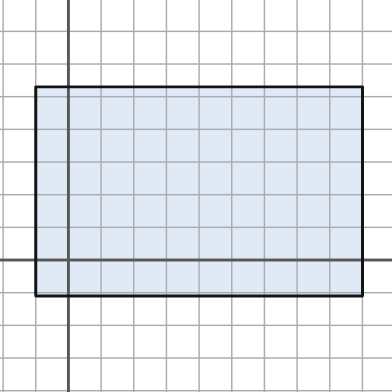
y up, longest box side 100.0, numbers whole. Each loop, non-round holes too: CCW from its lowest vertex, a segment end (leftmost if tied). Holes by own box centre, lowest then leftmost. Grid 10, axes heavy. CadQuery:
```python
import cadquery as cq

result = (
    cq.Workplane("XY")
    .moveTo(-10.0, -11.0)
    .lineTo(90.0, -11.0)
    .lineTo(90.0, 53.0)
    .lineTo(-10.0, 53.0)
    .close()
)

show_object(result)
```